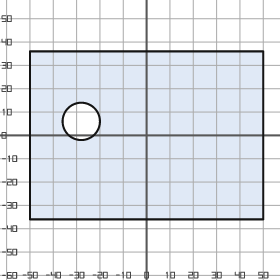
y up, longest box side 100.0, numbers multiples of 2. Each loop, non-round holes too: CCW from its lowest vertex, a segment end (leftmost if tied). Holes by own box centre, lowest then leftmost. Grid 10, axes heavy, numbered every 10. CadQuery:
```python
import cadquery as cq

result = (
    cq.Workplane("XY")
    .moveTo(-50.0, -36.0)
    .lineTo(50.0, -36.0)
    .lineTo(50.0, 36.0)
    .lineTo(-50.0, 36.0)
    .close()
    .moveTo(-28.0, 6.0)
    .circle(8.0)
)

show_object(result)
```